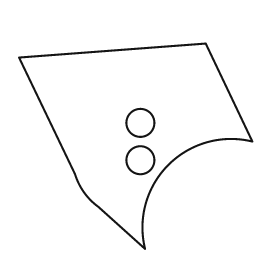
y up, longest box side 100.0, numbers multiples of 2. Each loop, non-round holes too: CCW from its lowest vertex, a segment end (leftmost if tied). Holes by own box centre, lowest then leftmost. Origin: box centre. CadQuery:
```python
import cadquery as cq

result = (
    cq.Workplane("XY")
    .moveTo(4.0, -44.0)
    .threePointArc((14.0, -8.0), (50.0, 2.0))
    .lineTo(30.0, 44.0)
    .lineTo(-50.0, 38.0)
    .lineTo(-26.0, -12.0)
    .threePointArc((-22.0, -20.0), (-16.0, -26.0))
    .close()
    .moveTo(2.0, -6.0)
    .circle(6.0)
    .moveTo(2.0, 10.0)
    .circle(6.0)
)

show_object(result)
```